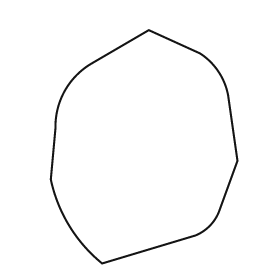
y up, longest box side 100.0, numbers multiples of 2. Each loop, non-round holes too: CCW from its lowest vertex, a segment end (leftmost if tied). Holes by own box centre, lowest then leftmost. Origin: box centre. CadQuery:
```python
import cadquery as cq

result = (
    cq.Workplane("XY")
    .moveTo(-18.0, -50.0)
    .lineTo(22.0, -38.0)
    .threePointArc((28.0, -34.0), (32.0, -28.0))
    .lineTo(40.0, -6.0)
    .lineTo(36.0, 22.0)
    .threePointArc((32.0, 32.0), (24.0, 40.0))
    .lineTo(2.0, 50.0)
    .lineTo(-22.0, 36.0)
    .threePointArc((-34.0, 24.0), (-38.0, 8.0))
    .lineTo(-40.0, -14.0)
    .threePointArc((-32.0, -34.0), (-18.0, -50.0))
    .close()
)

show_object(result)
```